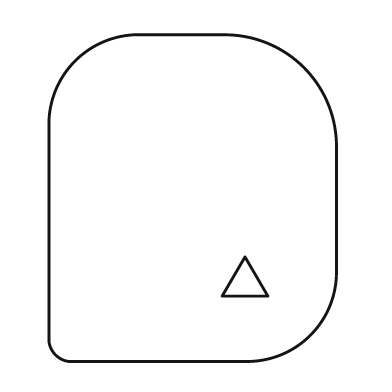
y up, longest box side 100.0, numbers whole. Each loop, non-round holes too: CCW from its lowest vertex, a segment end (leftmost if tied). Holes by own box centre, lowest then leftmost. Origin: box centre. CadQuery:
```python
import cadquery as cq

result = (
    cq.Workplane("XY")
    .moveTo(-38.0, -50.0)
    .lineTo(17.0, -50.0)
    .threePointArc((36.0, -42.0), (44.0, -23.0))
    .lineTo(44.0, 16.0)
    .threePointArc((34.0, 40.0), (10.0, 50.0))
    .lineTo(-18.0, 50.0)
    .threePointArc((-36.0, 42.0), (-44.0, 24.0))
    .lineTo(-44.0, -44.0)
    .threePointArc((-42.0, -48.0), (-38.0, -50.0))
    .close()
    .moveTo(9.0, -30.0)
    .lineTo(23.0, -30.0)
    .lineTo(16.0, -18.0)
    .close()
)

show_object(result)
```